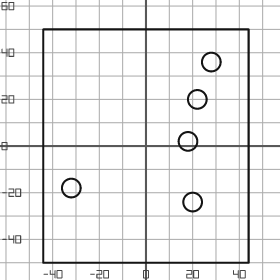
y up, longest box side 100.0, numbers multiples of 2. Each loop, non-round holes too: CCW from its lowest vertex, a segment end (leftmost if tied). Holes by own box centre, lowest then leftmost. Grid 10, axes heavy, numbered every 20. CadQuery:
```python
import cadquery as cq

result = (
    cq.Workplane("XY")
    .moveTo(-44.0, -50.0)
    .lineTo(44.0, -50.0)
    .lineTo(44.0, 50.0)
    .lineTo(-44.0, 50.0)
    .close()
    .moveTo(20.0, -24.0)
    .circle(4.0)
    .moveTo(-32.0, -18.0)
    .circle(4.0)
    .moveTo(18.0, 2.0)
    .circle(4.0)
    .moveTo(22.0, 20.0)
    .circle(4.0)
    .moveTo(28.0, 36.0)
    .circle(4.0)
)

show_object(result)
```